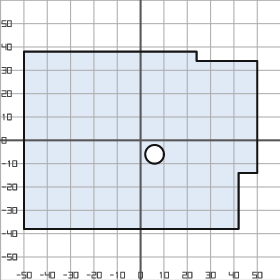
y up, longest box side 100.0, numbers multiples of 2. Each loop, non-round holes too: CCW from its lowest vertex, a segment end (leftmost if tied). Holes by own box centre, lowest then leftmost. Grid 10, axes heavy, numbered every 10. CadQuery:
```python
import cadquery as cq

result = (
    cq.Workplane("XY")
    .moveTo(-50.0, -38.0)
    .lineTo(42.0, -38.0)
    .lineTo(42.0, -14.0)
    .lineTo(50.0, -14.0)
    .lineTo(50.0, 34.0)
    .lineTo(24.0, 34.0)
    .lineTo(24.0, 38.0)
    .lineTo(-50.0, 38.0)
    .close()
    .moveTo(6.0, -6.0)
    .circle(4.0)
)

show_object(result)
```